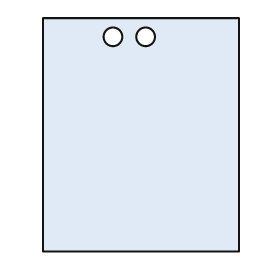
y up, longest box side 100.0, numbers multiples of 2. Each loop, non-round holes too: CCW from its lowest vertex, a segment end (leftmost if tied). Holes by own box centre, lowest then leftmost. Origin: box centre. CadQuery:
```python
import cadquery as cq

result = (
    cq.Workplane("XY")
    .moveTo(-42.0, -50.0)
    .lineTo(42.0, -50.0)
    .lineTo(42.0, 50.0)
    .lineTo(-42.0, 50.0)
    .close()
    .moveTo(-12.0, 42.0)
    .circle(4.0)
    .moveTo(2.0, 42.0)
    .circle(4.0)
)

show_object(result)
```